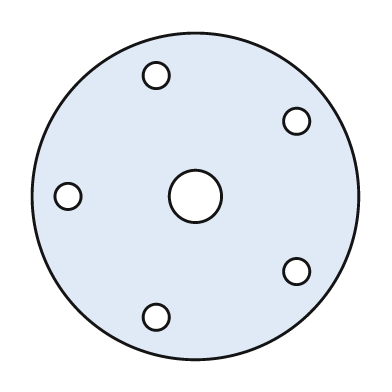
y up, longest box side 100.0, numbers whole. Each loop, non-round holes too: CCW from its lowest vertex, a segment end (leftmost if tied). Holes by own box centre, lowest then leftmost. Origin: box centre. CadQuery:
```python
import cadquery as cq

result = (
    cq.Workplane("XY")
    .moveTo(0.0, 0.0)
    .circle(50.0)
    .moveTo(-12.0, -37.0)
    .circle(4.0)
    .moveTo(31.0, -23.0)
    .circle(4.0)
    .moveTo(-39.0, 0.0)
    .circle(4.0)
    .moveTo(0.0, 0.0)
    .circle(8.0)
    .moveTo(31.0, 23.0)
    .circle(4.0)
    .moveTo(-12.0, 37.0)
    .circle(4.0)
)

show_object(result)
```